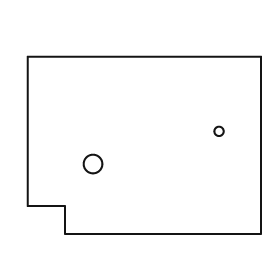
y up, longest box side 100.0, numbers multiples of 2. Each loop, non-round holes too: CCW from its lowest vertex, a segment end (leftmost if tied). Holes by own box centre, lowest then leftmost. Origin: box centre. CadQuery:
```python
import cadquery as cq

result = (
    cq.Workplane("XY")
    .moveTo(-34.0, -38.0)
    .lineTo(50.0, -38.0)
    .lineTo(50.0, 38.0)
    .lineTo(-50.0, 38.0)
    .lineTo(-50.0, -26.0)
    .lineTo(-34.0, -26.0)
    .close()
    .moveTo(-22.0, -8.0)
    .circle(4.0)
    .moveTo(32.0, 6.0)
    .circle(2.0)
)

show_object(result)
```